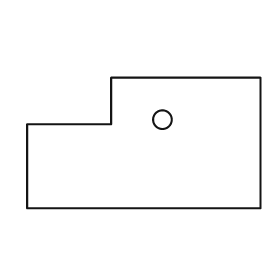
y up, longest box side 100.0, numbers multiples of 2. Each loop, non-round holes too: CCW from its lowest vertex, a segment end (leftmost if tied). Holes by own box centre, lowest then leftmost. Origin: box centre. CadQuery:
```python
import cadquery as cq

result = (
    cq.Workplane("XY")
    .moveTo(-50.0, -28.0)
    .lineTo(50.0, -28.0)
    .lineTo(50.0, 28.0)
    .lineTo(-14.0, 28.0)
    .lineTo(-14.0, 8.0)
    .lineTo(-50.0, 8.0)
    .close()
    .moveTo(8.0, 10.0)
    .circle(4.0)
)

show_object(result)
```